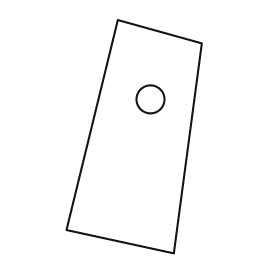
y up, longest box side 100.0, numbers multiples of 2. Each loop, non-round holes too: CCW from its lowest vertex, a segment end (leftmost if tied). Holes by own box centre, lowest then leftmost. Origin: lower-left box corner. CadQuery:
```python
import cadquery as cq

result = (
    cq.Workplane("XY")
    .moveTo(46.0, 0.0)
    .lineTo(58.0, 90.0)
    .lineTo(22.0, 100.0)
    .lineTo(0.0, 10.0)
    .close()
    .moveTo(36.0, 66.0)
    .circle(6.0)
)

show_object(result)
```